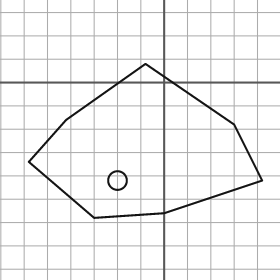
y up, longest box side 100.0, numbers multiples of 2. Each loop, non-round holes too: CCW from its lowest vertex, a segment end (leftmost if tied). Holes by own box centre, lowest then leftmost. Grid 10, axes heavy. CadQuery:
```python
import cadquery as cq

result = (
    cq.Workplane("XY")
    .moveTo(-30.0, -58.0)
    .lineTo(0.0, -56.0)
    .lineTo(42.0, -42.0)
    .lineTo(30.0, -18.0)
    .lineTo(-8.0, 8.0)
    .lineTo(-42.0, -16.0)
    .lineTo(-58.0, -34.0)
    .close()
    .moveTo(-20.0, -42.0)
    .circle(4.0)
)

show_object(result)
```